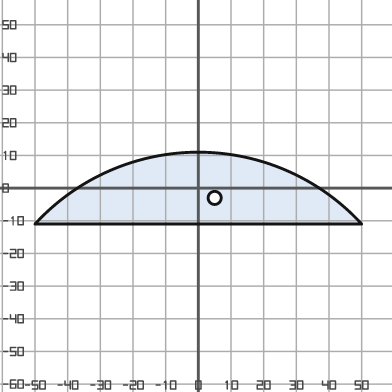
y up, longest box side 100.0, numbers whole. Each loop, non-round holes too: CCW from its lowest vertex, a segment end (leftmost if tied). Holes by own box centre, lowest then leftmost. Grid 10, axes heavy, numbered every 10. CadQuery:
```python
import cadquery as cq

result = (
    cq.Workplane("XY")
    .moveTo(-50.0, -11.0)
    .lineTo(50.0, -11.0)
    .threePointArc((0.0, 11.0), (-50.0, -11.0))
    .close()
    .moveTo(5.0, -3.0)
    .circle(2.0)
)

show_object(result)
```